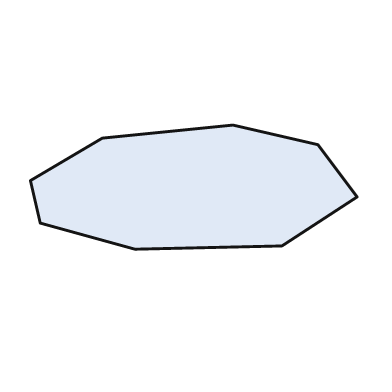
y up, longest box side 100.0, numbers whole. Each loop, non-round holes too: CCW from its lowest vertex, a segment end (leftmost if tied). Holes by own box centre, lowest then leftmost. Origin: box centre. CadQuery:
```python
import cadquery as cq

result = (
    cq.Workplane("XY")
    .moveTo(-18.0, -19.0)
    .lineTo(27.0, -18.0)
    .lineTo(50.0, -3.0)
    .lineTo(38.0, 13.0)
    .lineTo(12.0, 19.0)
    .lineTo(-28.0, 15.0)
    .lineTo(-50.0, 2.0)
    .lineTo(-47.0, -11.0)
    .close()
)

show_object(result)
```